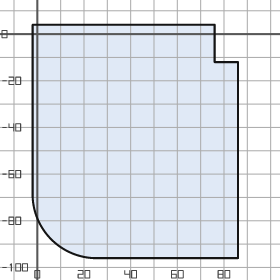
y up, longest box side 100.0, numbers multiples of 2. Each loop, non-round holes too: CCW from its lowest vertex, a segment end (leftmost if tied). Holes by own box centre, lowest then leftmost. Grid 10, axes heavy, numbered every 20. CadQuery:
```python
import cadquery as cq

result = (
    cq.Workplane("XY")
    .moveTo(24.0, -96.0)
    .lineTo(86.0, -96.0)
    .lineTo(86.0, -12.0)
    .lineTo(76.0, -12.0)
    .lineTo(76.0, 4.0)
    .lineTo(-2.0, 4.0)
    .lineTo(-2.0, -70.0)
    .threePointArc((6.0, -88.0), (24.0, -96.0))
    .close()
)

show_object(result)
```